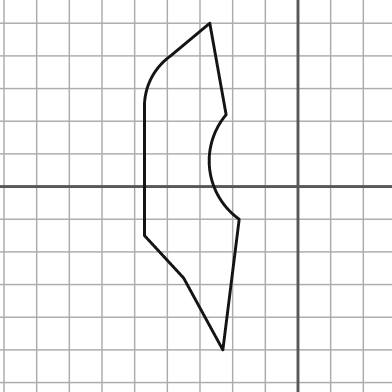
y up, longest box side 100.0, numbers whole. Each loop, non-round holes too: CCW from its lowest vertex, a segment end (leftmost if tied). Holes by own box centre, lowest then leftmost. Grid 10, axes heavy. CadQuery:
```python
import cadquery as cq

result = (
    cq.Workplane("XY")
    .moveTo(-23.0, -50.0)
    .lineTo(-18.0, -10.0)
    .threePointArc((-27.0, 5.0), (-22.0, 22.0))
    .lineTo(-27.0, 50.0)
    .lineTo(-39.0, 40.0)
    .threePointArc((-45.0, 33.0), (-47.0, 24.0))
    .lineTo(-47.0, -15.0)
    .lineTo(-35.0, -28.0)
    .close()
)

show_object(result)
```